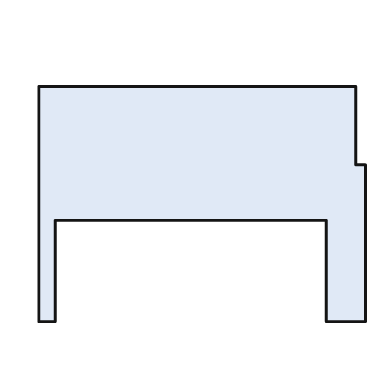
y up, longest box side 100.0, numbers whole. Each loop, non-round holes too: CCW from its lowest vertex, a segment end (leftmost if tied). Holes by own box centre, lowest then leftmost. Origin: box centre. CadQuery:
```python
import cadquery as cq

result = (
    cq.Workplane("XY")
    .moveTo(-50.0, -36.0)
    .lineTo(-45.0, -36.0)
    .lineTo(-45.0, -5.0)
    .lineTo(38.0, -5.0)
    .lineTo(38.0, -36.0)
    .lineTo(50.0, -36.0)
    .lineTo(50.0, 12.0)
    .lineTo(47.0, 12.0)
    .lineTo(47.0, 36.0)
    .lineTo(-50.0, 36.0)
    .close()
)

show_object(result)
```